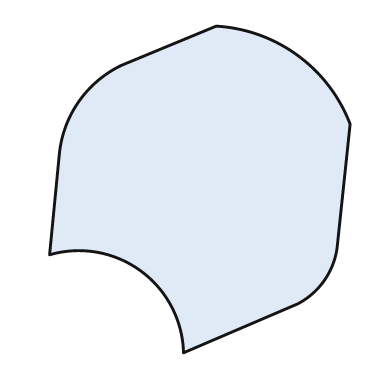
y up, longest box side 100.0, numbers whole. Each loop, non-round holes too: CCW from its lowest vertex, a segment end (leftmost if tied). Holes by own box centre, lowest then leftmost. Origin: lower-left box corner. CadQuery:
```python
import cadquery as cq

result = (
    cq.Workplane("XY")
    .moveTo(41.0, 0.0)
    .lineTo(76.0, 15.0)
    .threePointArc((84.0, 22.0), (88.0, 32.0))
    .lineTo(92.0, 70.0)
    .threePointArc((76.0, 91.0), (51.0, 100.0))
    .lineTo(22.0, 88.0)
    .threePointArc((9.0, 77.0), (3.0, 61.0))
    .lineTo(0.0, 30.0)
    .threePointArc((28.0, 25.0), (41.0, 0.0))
    .close()
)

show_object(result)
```